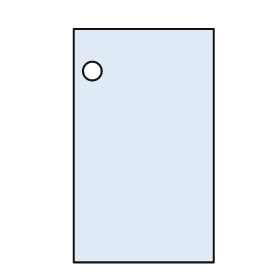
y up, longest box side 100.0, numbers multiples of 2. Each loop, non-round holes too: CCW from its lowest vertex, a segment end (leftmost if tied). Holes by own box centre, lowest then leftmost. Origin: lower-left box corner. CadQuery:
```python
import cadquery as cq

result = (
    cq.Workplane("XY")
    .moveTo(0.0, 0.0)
    .lineTo(60.0, 0.0)
    .lineTo(60.0, 100.0)
    .lineTo(0.0, 100.0)
    .close()
    .moveTo(8.0, 82.0)
    .circle(4.0)
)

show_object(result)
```